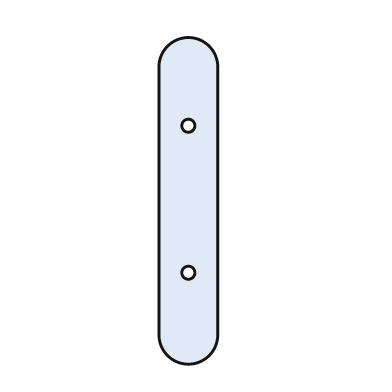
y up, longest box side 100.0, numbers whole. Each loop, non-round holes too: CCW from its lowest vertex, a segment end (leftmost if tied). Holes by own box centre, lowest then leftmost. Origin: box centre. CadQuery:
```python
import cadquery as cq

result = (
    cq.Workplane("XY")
    .moveTo(-9.0, -41.0)
    .threePointArc((0.0, -50.0), (9.0, -41.0))
    .lineTo(9.0, 41.0)
    .threePointArc((0.0, 50.0), (-9.0, 41.0))
    .close()
    .moveTo(0.0, -22.0)
    .circle(2.0)
    .moveTo(0.0, 23.0)
    .circle(2.0)
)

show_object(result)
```